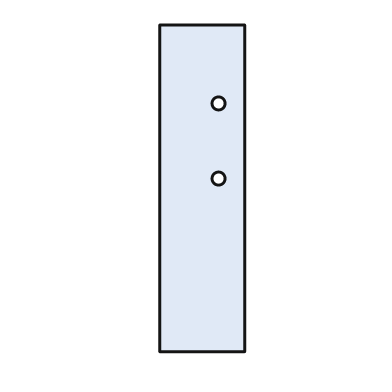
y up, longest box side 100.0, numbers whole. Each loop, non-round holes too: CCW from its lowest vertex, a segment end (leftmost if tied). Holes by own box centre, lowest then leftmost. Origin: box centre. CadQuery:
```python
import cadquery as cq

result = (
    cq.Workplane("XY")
    .moveTo(-13.0, -50.0)
    .lineTo(13.0, -50.0)
    .lineTo(13.0, 50.0)
    .lineTo(-13.0, 50.0)
    .close()
    .moveTo(5.0, 3.0)
    .circle(2.0)
    .moveTo(5.0, 26.0)
    .circle(2.0)
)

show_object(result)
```